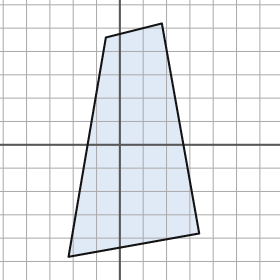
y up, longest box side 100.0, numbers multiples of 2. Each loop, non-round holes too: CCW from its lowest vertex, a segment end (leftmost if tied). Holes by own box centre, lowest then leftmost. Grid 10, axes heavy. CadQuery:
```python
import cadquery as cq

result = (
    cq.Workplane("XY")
    .moveTo(-22.0, -48.0)
    .lineTo(34.0, -38.0)
    .lineTo(18.0, 52.0)
    .lineTo(-6.0, 46.0)
    .close()
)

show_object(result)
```